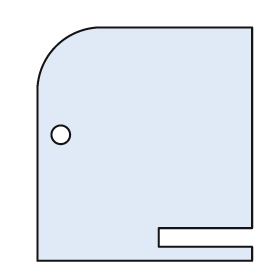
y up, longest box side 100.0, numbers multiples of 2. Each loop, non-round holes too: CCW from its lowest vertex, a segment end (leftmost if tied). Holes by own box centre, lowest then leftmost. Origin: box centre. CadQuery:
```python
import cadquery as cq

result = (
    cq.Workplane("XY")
    .moveTo(-46.0, -50.0)
    .lineTo(46.0, -50.0)
    .lineTo(46.0, -44.0)
    .lineTo(6.0, -44.0)
    .lineTo(6.0, -36.0)
    .lineTo(46.0, -36.0)
    .lineTo(46.0, 50.0)
    .lineTo(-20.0, 50.0)
    .threePointArc((-38.0, 42.0), (-46.0, 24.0))
    .close()
    .moveTo(-36.0, 4.0)
    .circle(4.0)
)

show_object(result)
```